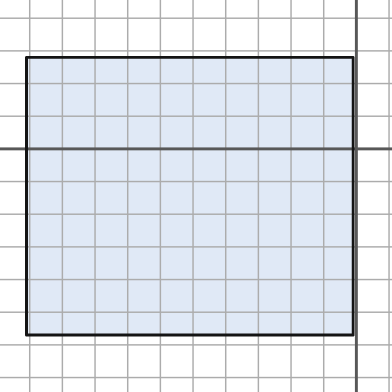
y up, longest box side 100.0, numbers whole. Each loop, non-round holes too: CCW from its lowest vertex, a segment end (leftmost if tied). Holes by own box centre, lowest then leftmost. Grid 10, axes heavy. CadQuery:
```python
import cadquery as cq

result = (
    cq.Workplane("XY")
    .moveTo(-101.0, -57.0)
    .lineTo(-1.0, -57.0)
    .lineTo(-1.0, 28.0)
    .lineTo(-101.0, 28.0)
    .close()
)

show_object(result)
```